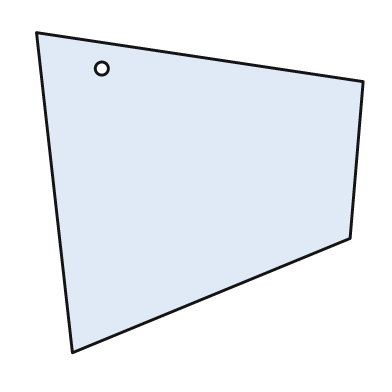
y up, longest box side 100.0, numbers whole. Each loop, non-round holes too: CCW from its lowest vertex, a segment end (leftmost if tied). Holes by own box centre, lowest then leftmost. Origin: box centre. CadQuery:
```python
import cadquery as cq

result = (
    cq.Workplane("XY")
    .moveTo(-39.0, -49.0)
    .lineTo(46.0, -14.0)
    .lineTo(50.0, 34.0)
    .lineTo(-50.0, 49.0)
    .close()
    .moveTo(-30.0, 38.0)
    .circle(2.0)
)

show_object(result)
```